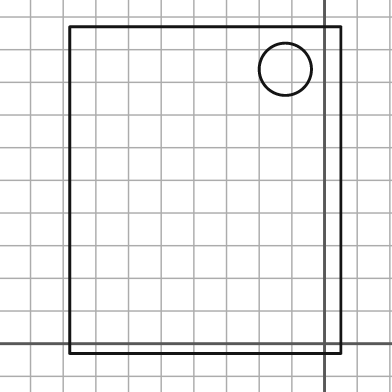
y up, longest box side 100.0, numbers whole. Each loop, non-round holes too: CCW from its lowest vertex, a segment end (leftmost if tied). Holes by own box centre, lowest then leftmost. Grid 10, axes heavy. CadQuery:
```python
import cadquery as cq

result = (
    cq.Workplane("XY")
    .moveTo(-78.0, -3.0)
    .lineTo(5.0, -3.0)
    .lineTo(5.0, 97.0)
    .lineTo(-78.0, 97.0)
    .close()
    .moveTo(-12.0, 84.0)
    .circle(8.0)
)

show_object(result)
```